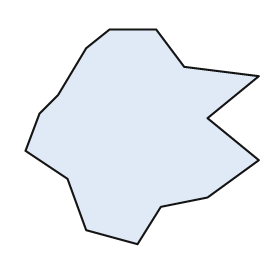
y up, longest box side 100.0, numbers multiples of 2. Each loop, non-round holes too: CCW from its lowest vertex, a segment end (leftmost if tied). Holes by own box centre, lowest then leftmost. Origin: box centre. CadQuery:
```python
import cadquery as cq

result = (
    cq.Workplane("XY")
    .moveTo(-2.0, -46.0)
    .lineTo(8.0, -30.0)
    .lineTo(28.0, -26.0)
    .lineTo(50.0, -10.0)
    .lineTo(28.0, 8.0)
    .lineTo(50.0, 26.0)
    .lineTo(18.0, 30.0)
    .lineTo(6.0, 46.0)
    .lineTo(-14.0, 46.0)
    .lineTo(-24.0, 38.0)
    .lineTo(-36.0, 18.0)
    .lineTo(-44.0, 10.0)
    .lineTo(-50.0, -6.0)
    .lineTo(-32.0, -18.0)
    .lineTo(-24.0, -40.0)
    .close()
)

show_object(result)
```